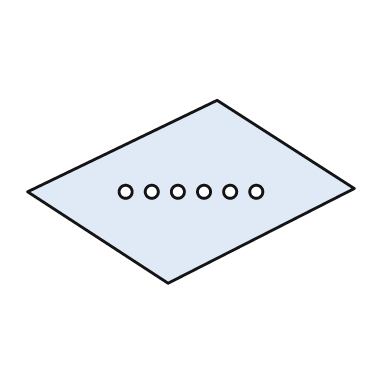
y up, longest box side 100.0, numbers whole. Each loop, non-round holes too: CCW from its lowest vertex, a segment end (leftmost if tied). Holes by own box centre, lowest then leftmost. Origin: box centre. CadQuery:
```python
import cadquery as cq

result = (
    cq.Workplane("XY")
    .moveTo(-7.0, -28.0)
    .lineTo(50.0, 1.0)
    .lineTo(8.0, 28.0)
    .lineTo(-50.0, 0.0)
    .close()
    .moveTo(-20.0, 0.0)
    .circle(2.0)
    .moveTo(-12.0, 0.0)
    .circle(2.0)
    .moveTo(-4.0, 0.0)
    .circle(2.0)
    .moveTo(4.0, 0.0)
    .circle(2.0)
    .moveTo(12.0, 0.0)
    .circle(2.0)
    .moveTo(20.0, 0.0)
    .circle(2.0)
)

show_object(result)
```